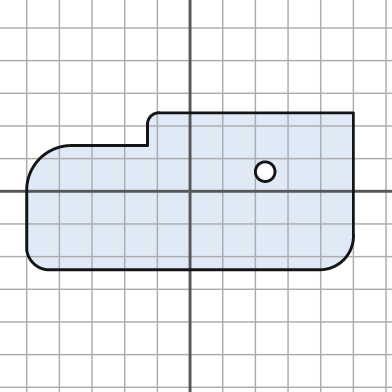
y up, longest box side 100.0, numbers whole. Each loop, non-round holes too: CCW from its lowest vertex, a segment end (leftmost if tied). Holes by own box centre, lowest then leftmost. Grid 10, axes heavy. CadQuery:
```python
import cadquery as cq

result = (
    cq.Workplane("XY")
    .moveTo(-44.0, -24.0)
    .lineTo(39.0, -24.0)
    .threePointArc((47.0, -21.0), (50.0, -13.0))
    .lineTo(50.0, 24.0)
    .lineTo(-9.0, 24.0)
    .threePointArc((-12.0, 23.0), (-13.0, 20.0))
    .lineTo(-13.0, 14.0)
    .lineTo(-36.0, 14.0)
    .threePointArc((-46.0, 10.0), (-50.0, 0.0))
    .lineTo(-50.0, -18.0)
    .threePointArc((-48.0, -22.0), (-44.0, -24.0))
    .close()
    .moveTo(23.0, 6.0)
    .circle(3.0)
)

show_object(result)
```